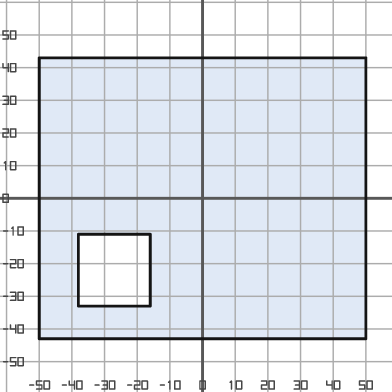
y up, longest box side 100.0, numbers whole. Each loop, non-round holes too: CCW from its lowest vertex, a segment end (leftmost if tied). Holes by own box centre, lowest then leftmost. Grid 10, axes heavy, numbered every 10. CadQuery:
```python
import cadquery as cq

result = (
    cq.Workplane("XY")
    .moveTo(-50.0, -43.0)
    .lineTo(50.0, -43.0)
    .lineTo(50.0, 43.0)
    .lineTo(-50.0, 43.0)
    .close()
    .moveTo(-38.0, -33.0)
    .lineTo(-16.0, -33.0)
    .lineTo(-16.0, -11.0)
    .lineTo(-38.0, -11.0)
    .close()
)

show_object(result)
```